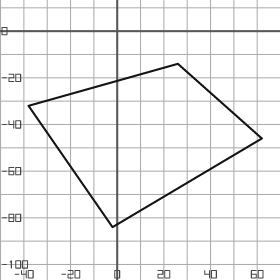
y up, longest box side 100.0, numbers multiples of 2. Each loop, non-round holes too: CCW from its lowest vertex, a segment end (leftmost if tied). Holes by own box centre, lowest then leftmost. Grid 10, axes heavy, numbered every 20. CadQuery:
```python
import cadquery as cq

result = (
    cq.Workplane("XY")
    .moveTo(-2.0, -84.0)
    .lineTo(62.0, -46.0)
    .lineTo(26.0, -14.0)
    .lineTo(-38.0, -32.0)
    .close()
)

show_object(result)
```